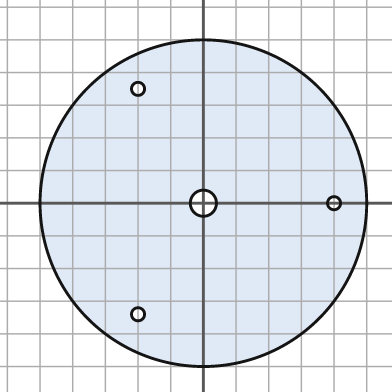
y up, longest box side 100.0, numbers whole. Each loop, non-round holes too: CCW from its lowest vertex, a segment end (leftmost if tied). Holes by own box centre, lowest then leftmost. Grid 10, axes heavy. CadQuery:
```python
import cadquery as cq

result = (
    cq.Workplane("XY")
    .moveTo(0.0, 0.0)
    .circle(50.0)
    .moveTo(-20.0, -34.0)
    .circle(2.0)
    .moveTo(0.0, 0.0)
    .circle(4.0)
    .moveTo(40.0, 0.0)
    .circle(2.0)
    .moveTo(-20.0, 35.0)
    .circle(2.0)
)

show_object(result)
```